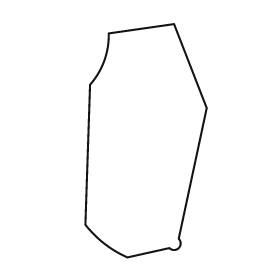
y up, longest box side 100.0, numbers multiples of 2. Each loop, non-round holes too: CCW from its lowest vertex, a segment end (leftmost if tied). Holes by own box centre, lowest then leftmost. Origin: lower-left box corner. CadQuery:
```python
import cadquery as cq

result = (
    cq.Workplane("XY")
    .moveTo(18.0, 0.0)
    .lineTo(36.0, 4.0)
    .threePointArc((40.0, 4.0), (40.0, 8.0))
    .lineTo(52.0, 64.0)
    .lineTo(38.0, 100.0)
    .lineTo(10.0, 96.0)
    .threePointArc((8.0, 84.0), (2.0, 74.0))
    .lineTo(0.0, 14.0)
    .threePointArc((8.0, 6.0), (18.0, 0.0))
    .close()
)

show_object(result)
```